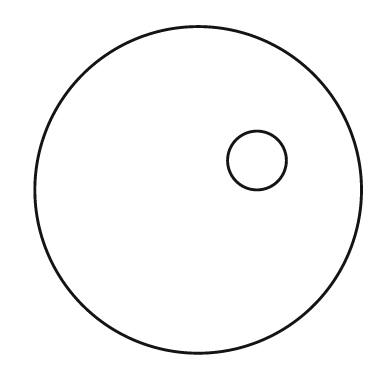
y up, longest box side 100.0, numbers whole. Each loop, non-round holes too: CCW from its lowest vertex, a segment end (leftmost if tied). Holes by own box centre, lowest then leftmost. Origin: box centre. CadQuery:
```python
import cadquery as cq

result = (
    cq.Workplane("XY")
    .moveTo(0.0, 0.0)
    .circle(50.0)
    .moveTo(18.0, 9.0)
    .circle(9.0)
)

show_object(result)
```